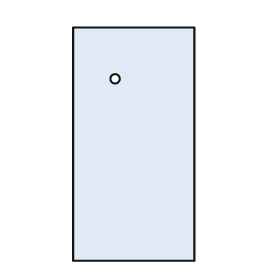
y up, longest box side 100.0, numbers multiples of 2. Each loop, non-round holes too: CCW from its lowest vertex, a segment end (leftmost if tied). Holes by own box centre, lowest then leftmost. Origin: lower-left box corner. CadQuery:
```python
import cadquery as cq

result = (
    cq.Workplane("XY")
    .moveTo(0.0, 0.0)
    .lineTo(52.0, 0.0)
    .lineTo(52.0, 100.0)
    .lineTo(0.0, 100.0)
    .close()
    .moveTo(18.0, 78.0)
    .circle(2.0)
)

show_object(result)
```